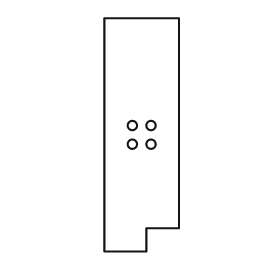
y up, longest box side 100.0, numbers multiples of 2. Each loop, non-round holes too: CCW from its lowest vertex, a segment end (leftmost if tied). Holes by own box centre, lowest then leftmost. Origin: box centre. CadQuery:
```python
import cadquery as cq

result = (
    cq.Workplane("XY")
    .moveTo(-16.0, -50.0)
    .lineTo(2.0, -50.0)
    .lineTo(2.0, -40.0)
    .lineTo(16.0, -40.0)
    .lineTo(16.0, 50.0)
    .lineTo(-16.0, 50.0)
    .close()
    .moveTo(-4.0, -4.0)
    .circle(2.0)
    .moveTo(4.0, -4.0)
    .circle(2.0)
    .moveTo(-4.0, 4.0)
    .circle(2.0)
    .moveTo(4.0, 4.0)
    .circle(2.0)
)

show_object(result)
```